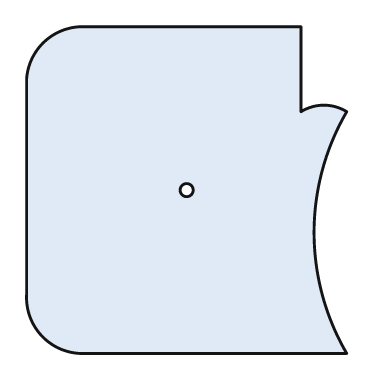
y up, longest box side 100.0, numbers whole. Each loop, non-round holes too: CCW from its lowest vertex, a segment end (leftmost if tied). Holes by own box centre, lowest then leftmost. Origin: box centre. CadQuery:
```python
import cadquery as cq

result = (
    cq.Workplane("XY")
    .moveTo(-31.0, -50.0)
    .lineTo(49.0, -50.0)
    .threePointArc((39.0, -13.0), (49.0, 24.0))
    .threePointArc((42.0, 26.0), (35.0, 24.0))
    .lineTo(35.0, 50.0)
    .lineTo(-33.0, 50.0)
    .threePointArc((-44.0, 45.0), (-49.0, 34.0))
    .lineTo(-49.0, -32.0)
    .threePointArc((-44.0, -45.0), (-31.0, -50.0))
    .close()
    .moveTo(0.0, 0.0)
    .circle(2.0)
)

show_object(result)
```